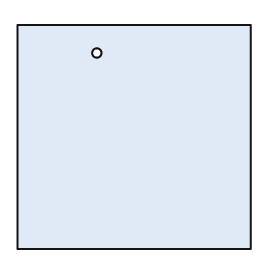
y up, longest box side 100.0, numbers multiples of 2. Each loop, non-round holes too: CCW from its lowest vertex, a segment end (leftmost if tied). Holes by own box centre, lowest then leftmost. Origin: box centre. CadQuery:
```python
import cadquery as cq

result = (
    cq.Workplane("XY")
    .moveTo(-50.0, -48.0)
    .lineTo(50.0, -48.0)
    .lineTo(50.0, 48.0)
    .lineTo(-50.0, 48.0)
    .close()
    .moveTo(-16.0, 36.0)
    .circle(2.0)
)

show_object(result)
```